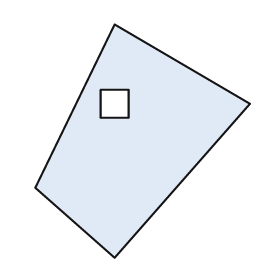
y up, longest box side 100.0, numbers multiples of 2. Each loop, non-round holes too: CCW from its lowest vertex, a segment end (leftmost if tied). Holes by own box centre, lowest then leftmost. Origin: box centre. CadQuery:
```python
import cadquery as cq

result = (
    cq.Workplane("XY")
    .moveTo(-12.0, -50.0)
    .lineTo(46.0, 16.0)
    .lineTo(-12.0, 50.0)
    .lineTo(-46.0, -20.0)
    .close()
    .moveTo(-18.0, 10.0)
    .lineTo(-6.0, 10.0)
    .lineTo(-6.0, 22.0)
    .lineTo(-18.0, 22.0)
    .close()
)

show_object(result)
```